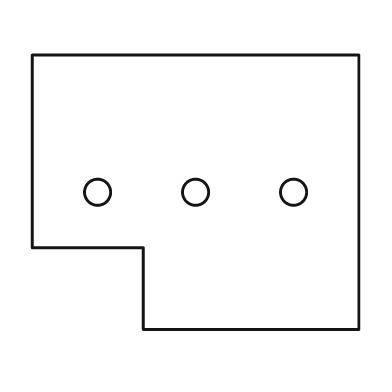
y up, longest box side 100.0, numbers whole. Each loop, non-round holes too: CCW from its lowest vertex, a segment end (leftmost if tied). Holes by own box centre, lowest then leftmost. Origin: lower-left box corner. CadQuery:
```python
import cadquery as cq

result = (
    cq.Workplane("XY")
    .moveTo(34.0, 0.0)
    .lineTo(100.0, 0.0)
    .lineTo(100.0, 84.0)
    .lineTo(0.0, 84.0)
    .lineTo(0.0, 25.0)
    .lineTo(34.0, 25.0)
    .close()
    .moveTo(20.0, 42.0)
    .circle(4.0)
    .moveTo(50.0, 42.0)
    .circle(4.0)
    .moveTo(80.0, 42.0)
    .circle(4.0)
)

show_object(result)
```